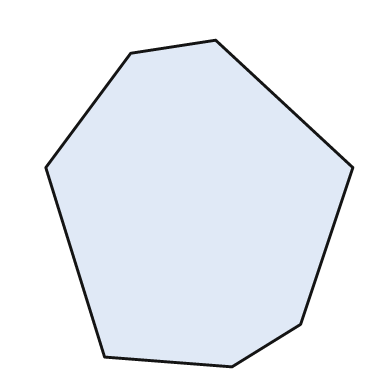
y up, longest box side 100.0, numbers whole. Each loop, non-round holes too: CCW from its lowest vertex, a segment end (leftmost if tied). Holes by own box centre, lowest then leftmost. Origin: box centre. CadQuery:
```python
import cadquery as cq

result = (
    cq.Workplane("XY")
    .moveTo(10.0, -50.0)
    .lineTo(31.0, -37.0)
    .lineTo(47.0, 11.0)
    .lineTo(5.0, 50.0)
    .lineTo(-21.0, 46.0)
    .lineTo(-47.0, 11.0)
    .lineTo(-29.0, -47.0)
    .close()
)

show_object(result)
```